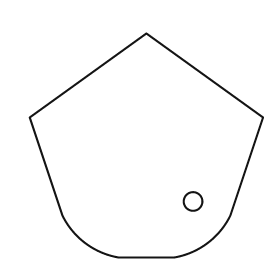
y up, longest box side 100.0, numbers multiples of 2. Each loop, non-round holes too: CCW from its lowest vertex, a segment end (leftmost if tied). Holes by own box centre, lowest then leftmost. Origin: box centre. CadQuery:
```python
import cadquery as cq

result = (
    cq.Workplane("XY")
    .moveTo(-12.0, -48.0)
    .lineTo(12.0, -48.0)
    .threePointArc((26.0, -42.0), (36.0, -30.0))
    .lineTo(50.0, 12.0)
    .lineTo(0.0, 48.0)
    .lineTo(-50.0, 12.0)
    .lineTo(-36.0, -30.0)
    .threePointArc((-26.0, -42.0), (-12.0, -48.0))
    .close()
    .moveTo(20.0, -24.0)
    .circle(4.0)
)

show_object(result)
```